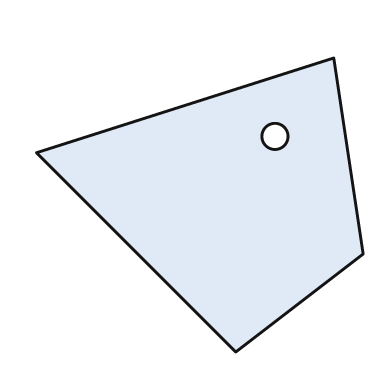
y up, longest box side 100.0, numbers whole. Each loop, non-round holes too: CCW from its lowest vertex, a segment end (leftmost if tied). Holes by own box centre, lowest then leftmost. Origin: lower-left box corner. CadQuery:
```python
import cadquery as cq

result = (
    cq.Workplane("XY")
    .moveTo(61.0, 0.0)
    .lineTo(100.0, 30.0)
    .lineTo(91.0, 90.0)
    .lineTo(0.0, 61.0)
    .close()
    .moveTo(73.0, 66.0)
    .circle(4.0)
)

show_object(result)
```